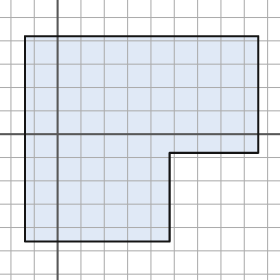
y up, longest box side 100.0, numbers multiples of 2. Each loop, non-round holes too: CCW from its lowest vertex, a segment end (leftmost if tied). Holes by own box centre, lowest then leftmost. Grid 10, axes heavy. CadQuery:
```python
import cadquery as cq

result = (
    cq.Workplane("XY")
    .moveTo(-14.0, -46.0)
    .lineTo(48.0, -46.0)
    .lineTo(48.0, -8.0)
    .lineTo(86.0, -8.0)
    .lineTo(86.0, 42.0)
    .lineTo(-14.0, 42.0)
    .close()
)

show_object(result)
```